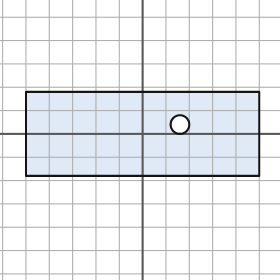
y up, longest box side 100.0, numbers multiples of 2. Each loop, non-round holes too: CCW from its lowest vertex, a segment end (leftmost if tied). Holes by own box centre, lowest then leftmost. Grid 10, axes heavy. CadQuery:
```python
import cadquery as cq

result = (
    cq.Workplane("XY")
    .moveTo(-50.0, -18.0)
    .lineTo(50.0, -18.0)
    .lineTo(50.0, 18.0)
    .lineTo(-50.0, 18.0)
    .close()
    .moveTo(16.0, 4.0)
    .circle(4.0)
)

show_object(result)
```